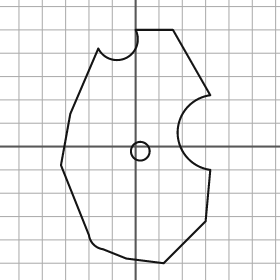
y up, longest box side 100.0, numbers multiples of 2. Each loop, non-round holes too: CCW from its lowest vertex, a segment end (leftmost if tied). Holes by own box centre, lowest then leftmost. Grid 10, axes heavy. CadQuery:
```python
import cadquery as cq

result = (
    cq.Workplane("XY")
    .moveTo(12.0, -50.0)
    .lineTo(30.0, -32.0)
    .lineTo(32.0, -10.0)
    .threePointArc((18.0, 6.0), (32.0, 22.0))
    .lineTo(16.0, 50.0)
    .lineTo(0.0, 50.0)
    .threePointArc((-4.0, 38.0), (-16.0, 42.0))
    .lineTo(-28.0, 14.0)
    .lineTo(-32.0, -8.0)
    .lineTo(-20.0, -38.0)
    .threePointArc((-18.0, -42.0), (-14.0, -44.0))
    .lineTo(-4.0, -48.0)
    .close()
    .moveTo(2.0, -2.0)
    .circle(4.0)
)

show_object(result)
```